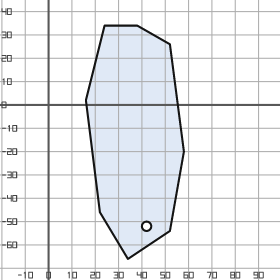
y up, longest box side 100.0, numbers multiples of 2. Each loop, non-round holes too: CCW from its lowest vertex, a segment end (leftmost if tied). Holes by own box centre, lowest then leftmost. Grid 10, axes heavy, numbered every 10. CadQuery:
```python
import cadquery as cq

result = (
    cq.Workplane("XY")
    .moveTo(34.0, -66.0)
    .lineTo(52.0, -54.0)
    .lineTo(58.0, -20.0)
    .lineTo(52.0, 26.0)
    .lineTo(38.0, 34.0)
    .lineTo(24.0, 34.0)
    .lineTo(16.0, 2.0)
    .lineTo(22.0, -46.0)
    .close()
    .moveTo(42.0, -52.0)
    .circle(2.0)
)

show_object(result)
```